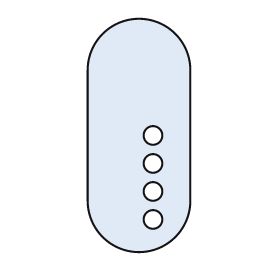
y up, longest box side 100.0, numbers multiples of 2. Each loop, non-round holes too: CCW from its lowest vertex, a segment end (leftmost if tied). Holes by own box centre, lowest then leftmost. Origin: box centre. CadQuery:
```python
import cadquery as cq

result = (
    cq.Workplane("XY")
    .moveTo(-22.0, -28.0)
    .threePointArc((0.0, -50.0), (22.0, -28.0))
    .lineTo(22.0, 28.0)
    .threePointArc((0.0, 50.0), (-22.0, 28.0))
    .close()
    .moveTo(6.0, -36.0)
    .circle(4.0)
    .moveTo(6.0, -24.0)
    .circle(4.0)
    .moveTo(6.0, -12.0)
    .circle(4.0)
    .moveTo(6.0, 0.0)
    .circle(4.0)
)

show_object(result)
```